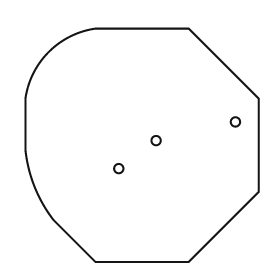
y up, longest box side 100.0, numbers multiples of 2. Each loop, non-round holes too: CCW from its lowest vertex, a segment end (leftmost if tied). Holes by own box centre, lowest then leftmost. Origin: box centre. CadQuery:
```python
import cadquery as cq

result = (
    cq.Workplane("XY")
    .moveTo(-20.0, -50.0)
    .lineTo(20.0, -50.0)
    .lineTo(50.0, -20.0)
    .lineTo(50.0, 20.0)
    .lineTo(20.0, 50.0)
    .lineTo(-20.0, 50.0)
    .threePointArc((-40.0, 40.0), (-50.0, 20.0))
    .lineTo(-50.0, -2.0)
    .threePointArc((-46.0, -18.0), (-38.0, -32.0))
    .close()
    .moveTo(-10.0, -10.0)
    .circle(2.0)
    .moveTo(6.0, 2.0)
    .circle(2.0)
    .moveTo(40.0, 10.0)
    .circle(2.0)
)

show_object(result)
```